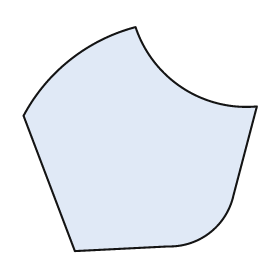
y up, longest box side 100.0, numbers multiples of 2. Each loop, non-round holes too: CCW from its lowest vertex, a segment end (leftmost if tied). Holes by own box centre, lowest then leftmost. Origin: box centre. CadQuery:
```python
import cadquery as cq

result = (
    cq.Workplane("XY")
    .moveTo(-28.0, -48.0)
    .lineTo(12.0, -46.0)
    .threePointArc((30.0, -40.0), (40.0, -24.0))
    .lineTo(50.0, 14.0)
    .threePointArc((18.0, 22.0), (-2.0, 48.0))
    .threePointArc((-30.0, 34.0), (-50.0, 10.0))
    .close()
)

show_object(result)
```